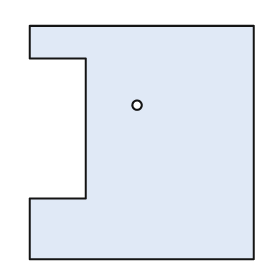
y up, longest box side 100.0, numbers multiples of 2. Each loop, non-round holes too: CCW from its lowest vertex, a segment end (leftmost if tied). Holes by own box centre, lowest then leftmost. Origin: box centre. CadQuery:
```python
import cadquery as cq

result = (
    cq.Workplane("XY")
    .moveTo(-48.0, -50.0)
    .lineTo(48.0, -50.0)
    .lineTo(48.0, 50.0)
    .lineTo(-48.0, 50.0)
    .lineTo(-48.0, 36.0)
    .lineTo(-24.0, 36.0)
    .lineTo(-24.0, -24.0)
    .lineTo(-48.0, -24.0)
    .close()
    .moveTo(-2.0, 16.0)
    .circle(2.0)
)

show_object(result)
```